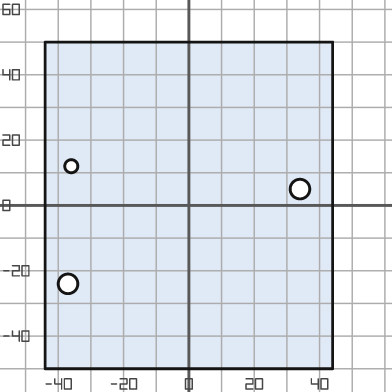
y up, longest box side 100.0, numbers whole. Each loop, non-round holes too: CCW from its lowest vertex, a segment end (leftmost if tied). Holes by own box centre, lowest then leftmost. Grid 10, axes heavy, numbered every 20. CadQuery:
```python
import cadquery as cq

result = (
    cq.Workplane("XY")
    .moveTo(-44.0, -50.0)
    .lineTo(44.0, -50.0)
    .lineTo(44.0, 50.0)
    .lineTo(-44.0, 50.0)
    .close()
    .moveTo(-37.0, -24.0)
    .circle(3.0)
    .moveTo(34.0, 5.0)
    .circle(3.0)
    .moveTo(-36.0, 12.0)
    .circle(2.0)
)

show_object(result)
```